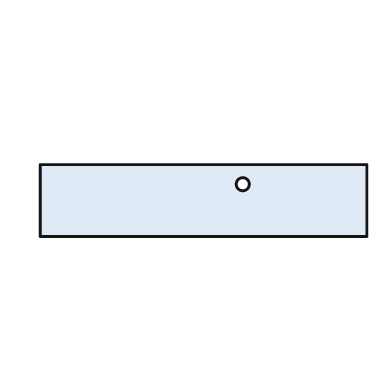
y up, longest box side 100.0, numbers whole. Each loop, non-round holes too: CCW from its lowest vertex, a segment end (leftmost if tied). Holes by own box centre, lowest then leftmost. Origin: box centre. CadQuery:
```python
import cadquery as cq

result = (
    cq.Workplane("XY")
    .moveTo(-50.0, -11.0)
    .lineTo(50.0, -11.0)
    .lineTo(50.0, 11.0)
    .lineTo(-50.0, 11.0)
    .close()
    .moveTo(12.0, 5.0)
    .circle(2.0)
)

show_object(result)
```